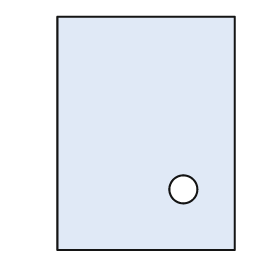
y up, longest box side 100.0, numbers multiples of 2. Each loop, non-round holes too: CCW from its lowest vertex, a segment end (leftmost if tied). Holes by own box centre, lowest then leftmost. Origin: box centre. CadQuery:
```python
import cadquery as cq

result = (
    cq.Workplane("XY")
    .moveTo(-38.0, -50.0)
    .lineTo(38.0, -50.0)
    .lineTo(38.0, 50.0)
    .lineTo(-38.0, 50.0)
    .close()
    .moveTo(16.0, -24.0)
    .circle(6.0)
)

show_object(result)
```